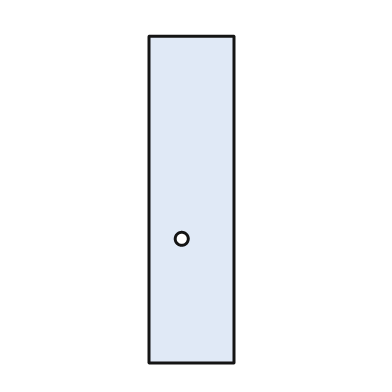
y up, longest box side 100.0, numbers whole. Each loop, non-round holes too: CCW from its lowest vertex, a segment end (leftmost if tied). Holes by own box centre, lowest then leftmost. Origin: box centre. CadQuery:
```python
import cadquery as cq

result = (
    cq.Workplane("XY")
    .moveTo(-13.0, -50.0)
    .lineTo(13.0, -50.0)
    .lineTo(13.0, 50.0)
    .lineTo(-13.0, 50.0)
    .close()
    .moveTo(-3.0, -12.0)
    .circle(2.0)
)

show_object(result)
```